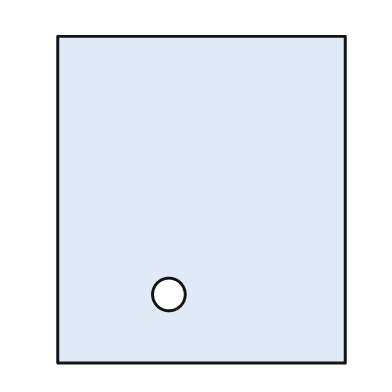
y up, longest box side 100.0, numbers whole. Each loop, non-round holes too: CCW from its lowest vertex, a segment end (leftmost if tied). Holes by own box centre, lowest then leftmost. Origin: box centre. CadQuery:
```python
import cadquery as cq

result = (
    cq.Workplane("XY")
    .moveTo(-44.0, -50.0)
    .lineTo(44.0, -50.0)
    .lineTo(44.0, 50.0)
    .lineTo(-44.0, 50.0)
    .close()
    .moveTo(-10.0, -29.0)
    .circle(5.0)
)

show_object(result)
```